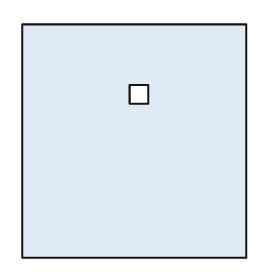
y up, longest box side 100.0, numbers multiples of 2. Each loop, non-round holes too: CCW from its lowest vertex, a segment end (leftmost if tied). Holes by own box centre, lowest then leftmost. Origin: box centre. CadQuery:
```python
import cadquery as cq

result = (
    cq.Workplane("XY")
    .moveTo(-48.0, -50.0)
    .lineTo(48.0, -50.0)
    .lineTo(48.0, 50.0)
    .lineTo(-48.0, 50.0)
    .close()
    .moveTo(-2.0, 16.0)
    .lineTo(6.0, 16.0)
    .lineTo(6.0, 24.0)
    .lineTo(-2.0, 24.0)
    .close()
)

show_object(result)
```